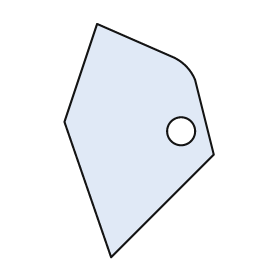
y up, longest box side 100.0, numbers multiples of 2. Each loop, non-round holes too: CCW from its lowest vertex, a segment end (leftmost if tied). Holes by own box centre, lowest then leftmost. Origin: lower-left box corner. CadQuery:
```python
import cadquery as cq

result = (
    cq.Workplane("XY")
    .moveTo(20.0, 0.0)
    .lineTo(64.0, 44.0)
    .lineTo(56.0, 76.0)
    .threePointArc((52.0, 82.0), (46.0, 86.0))
    .lineTo(14.0, 100.0)
    .lineTo(0.0, 58.0)
    .close()
    .moveTo(50.0, 54.0)
    .circle(6.0)
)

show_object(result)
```